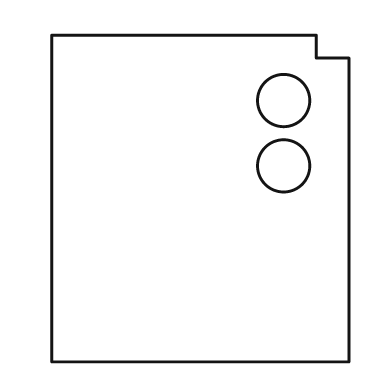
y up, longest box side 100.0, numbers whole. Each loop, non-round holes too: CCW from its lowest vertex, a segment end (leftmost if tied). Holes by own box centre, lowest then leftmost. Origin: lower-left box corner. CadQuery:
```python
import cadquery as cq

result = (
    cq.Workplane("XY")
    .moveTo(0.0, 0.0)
    .lineTo(91.0, 0.0)
    .lineTo(91.0, 93.0)
    .lineTo(81.0, 93.0)
    .lineTo(81.0, 100.0)
    .lineTo(0.0, 100.0)
    .close()
    .moveTo(71.0, 60.0)
    .circle(8.0)
    .moveTo(71.0, 80.0)
    .circle(8.0)
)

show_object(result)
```